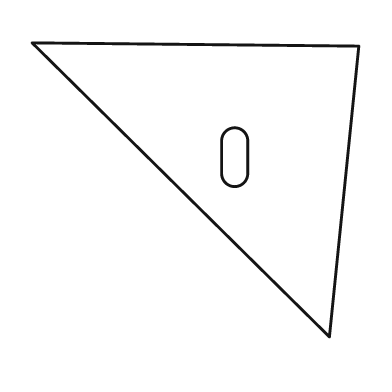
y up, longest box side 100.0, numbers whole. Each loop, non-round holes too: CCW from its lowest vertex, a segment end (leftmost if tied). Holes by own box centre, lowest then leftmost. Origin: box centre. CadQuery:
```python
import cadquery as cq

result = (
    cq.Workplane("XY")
    .moveTo(41.0, -45.0)
    .lineTo(50.0, 44.0)
    .lineTo(-50.0, 45.0)
    .close()
    .moveTo(8.0, 5.0)
    .threePointArc((12.0, 1.0), (16.0, 5.0))
    .lineTo(16.0, 15.0)
    .threePointArc((12.0, 19.0), (8.0, 15.0))
    .close()
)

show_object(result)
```